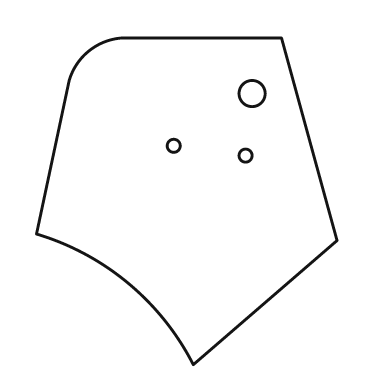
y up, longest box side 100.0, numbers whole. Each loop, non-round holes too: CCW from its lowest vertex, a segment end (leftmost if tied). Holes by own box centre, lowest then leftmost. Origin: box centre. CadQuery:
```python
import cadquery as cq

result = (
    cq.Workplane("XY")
    .moveTo(2.0, -50.0)
    .lineTo(46.0, -12.0)
    .lineTo(29.0, 50.0)
    .lineTo(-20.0, 50.0)
    .threePointArc((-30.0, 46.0), (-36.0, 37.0))
    .lineTo(-46.0, -10.0)
    .threePointArc((-18.0, -25.0), (2.0, -50.0))
    .close()
    .moveTo(18.0, 14.0)
    .circle(2.0)
    .moveTo(-4.0, 17.0)
    .circle(2.0)
    .moveTo(20.0, 33.0)
    .circle(4.0)
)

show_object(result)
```